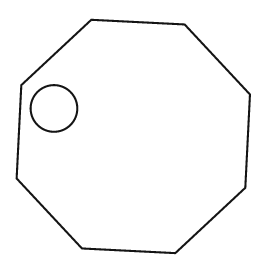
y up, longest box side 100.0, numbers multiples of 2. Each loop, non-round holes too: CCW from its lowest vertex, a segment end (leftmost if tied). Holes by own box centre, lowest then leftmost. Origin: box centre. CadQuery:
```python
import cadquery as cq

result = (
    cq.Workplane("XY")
    .moveTo(18.0, -50.0)
    .lineTo(48.0, -22.0)
    .lineTo(50.0, 18.0)
    .lineTo(22.0, 48.0)
    .lineTo(-18.0, 50.0)
    .lineTo(-48.0, 22.0)
    .lineTo(-50.0, -18.0)
    .lineTo(-22.0, -48.0)
    .close()
    .moveTo(-34.0, 12.0)
    .circle(10.0)
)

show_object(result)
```